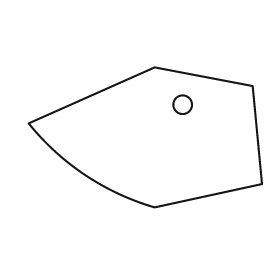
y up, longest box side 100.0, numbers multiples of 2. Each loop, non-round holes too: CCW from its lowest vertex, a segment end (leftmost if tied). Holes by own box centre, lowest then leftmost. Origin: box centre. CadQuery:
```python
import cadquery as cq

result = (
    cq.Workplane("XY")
    .moveTo(4.0, -30.0)
    .lineTo(50.0, -20.0)
    .lineTo(46.0, 22.0)
    .lineTo(4.0, 30.0)
    .lineTo(-50.0, 6.0)
    .threePointArc((-26.0, -16.0), (4.0, -30.0))
    .close()
    .moveTo(16.0, 14.0)
    .circle(4.0)
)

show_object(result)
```